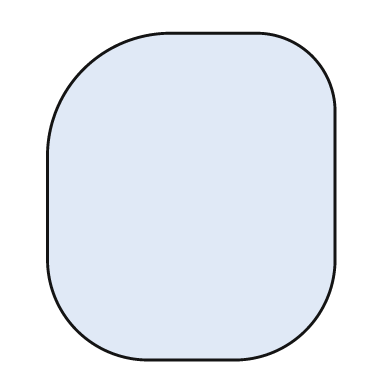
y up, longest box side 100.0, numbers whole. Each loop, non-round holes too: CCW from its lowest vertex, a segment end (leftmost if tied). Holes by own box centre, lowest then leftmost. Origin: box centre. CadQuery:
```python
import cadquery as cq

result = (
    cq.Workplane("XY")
    .moveTo(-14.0, -50.0)
    .lineTo(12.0, -50.0)
    .threePointArc((35.0, -41.0), (44.0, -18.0))
    .lineTo(44.0, 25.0)
    .threePointArc((37.0, 43.0), (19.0, 50.0))
    .lineTo(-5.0, 50.0)
    .threePointArc((-33.0, 39.0), (-44.0, 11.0))
    .lineTo(-44.0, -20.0)
    .threePointArc((-35.0, -41.0), (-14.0, -50.0))
    .close()
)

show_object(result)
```